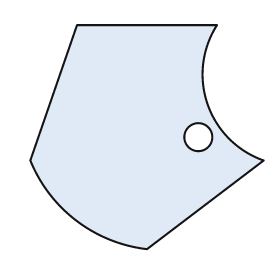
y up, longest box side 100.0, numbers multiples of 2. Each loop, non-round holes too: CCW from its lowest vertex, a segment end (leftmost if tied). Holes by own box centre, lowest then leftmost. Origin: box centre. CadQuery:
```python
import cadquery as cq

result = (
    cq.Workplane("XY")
    .moveTo(0.0, -48.0)
    .lineTo(50.0, -10.0)
    .threePointArc((26.0, 14.0), (30.0, 48.0))
    .lineTo(-30.0, 48.0)
    .lineTo(-50.0, -10.0)
    .threePointArc((-30.0, -36.0), (0.0, -48.0))
    .close()
    .moveTo(22.0, 0.0)
    .circle(6.0)
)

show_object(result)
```